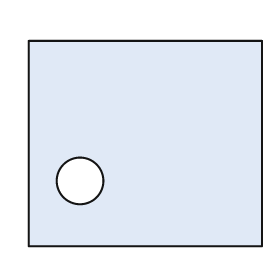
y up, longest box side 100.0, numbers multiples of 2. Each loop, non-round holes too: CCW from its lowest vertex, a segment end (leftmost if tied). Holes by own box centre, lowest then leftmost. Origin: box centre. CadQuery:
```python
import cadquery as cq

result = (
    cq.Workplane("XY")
    .moveTo(-50.0, -44.0)
    .lineTo(50.0, -44.0)
    .lineTo(50.0, 44.0)
    .lineTo(-50.0, 44.0)
    .close()
    .moveTo(-28.0, -16.0)
    .circle(10.0)
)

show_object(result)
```